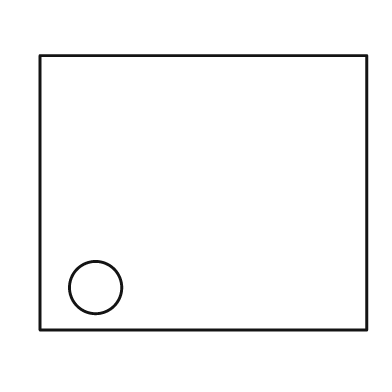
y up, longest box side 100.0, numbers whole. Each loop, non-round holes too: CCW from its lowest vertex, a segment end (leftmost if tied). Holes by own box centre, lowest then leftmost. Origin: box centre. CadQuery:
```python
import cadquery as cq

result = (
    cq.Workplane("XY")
    .moveTo(-50.0, -42.0)
    .lineTo(50.0, -42.0)
    .lineTo(50.0, 42.0)
    .lineTo(-50.0, 42.0)
    .close()
    .moveTo(-33.0, -29.0)
    .circle(8.0)
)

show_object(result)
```